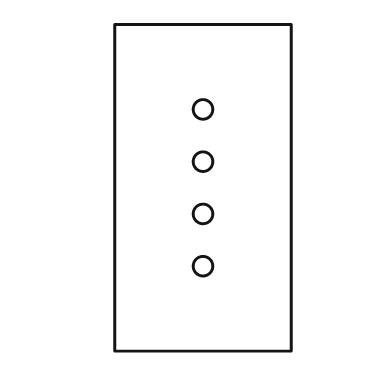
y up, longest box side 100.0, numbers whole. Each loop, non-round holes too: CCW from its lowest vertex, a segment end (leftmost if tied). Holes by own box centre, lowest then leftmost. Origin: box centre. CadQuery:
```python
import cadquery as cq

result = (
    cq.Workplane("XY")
    .moveTo(-27.0, -50.0)
    .lineTo(27.0, -50.0)
    .lineTo(27.0, 50.0)
    .lineTo(-27.0, 50.0)
    .close()
    .moveTo(0.0, -24.0)
    .circle(3.0)
    .moveTo(0.0, -8.0)
    .circle(3.0)
    .moveTo(0.0, 8.0)
    .circle(3.0)
    .moveTo(0.0, 24.0)
    .circle(3.0)
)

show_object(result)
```